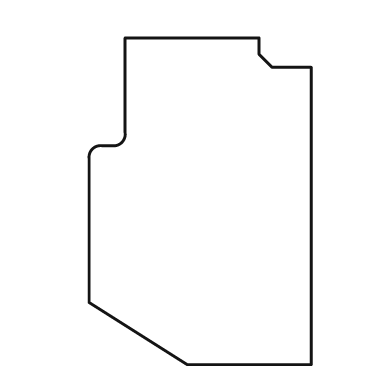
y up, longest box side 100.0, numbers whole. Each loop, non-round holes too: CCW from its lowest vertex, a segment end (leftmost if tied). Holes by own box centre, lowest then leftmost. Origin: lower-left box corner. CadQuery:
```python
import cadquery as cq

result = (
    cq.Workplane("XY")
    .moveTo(30.0, 0.0)
    .lineTo(68.0, 0.0)
    .lineTo(68.0, 91.0)
    .lineTo(56.0, 91.0)
    .lineTo(52.0, 95.0)
    .lineTo(52.0, 100.0)
    .lineTo(11.0, 100.0)
    .lineTo(11.0, 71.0)
    .threePointArc((10.0, 68.0), (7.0, 67.0))
    .lineTo(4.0, 67.0)
    .threePointArc((1.0, 66.0), (0.0, 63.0))
    .lineTo(0.0, 19.0)
    .close()
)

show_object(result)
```